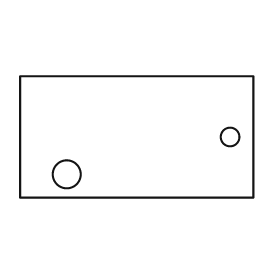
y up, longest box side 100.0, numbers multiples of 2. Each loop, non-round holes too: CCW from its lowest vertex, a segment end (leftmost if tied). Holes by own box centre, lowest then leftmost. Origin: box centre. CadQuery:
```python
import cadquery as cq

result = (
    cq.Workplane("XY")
    .moveTo(-50.0, -26.0)
    .lineTo(50.0, -26.0)
    .lineTo(50.0, 26.0)
    .lineTo(-50.0, 26.0)
    .close()
    .moveTo(-30.0, -16.0)
    .circle(6.0)
    .moveTo(40.0, 0.0)
    .circle(4.0)
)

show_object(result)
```